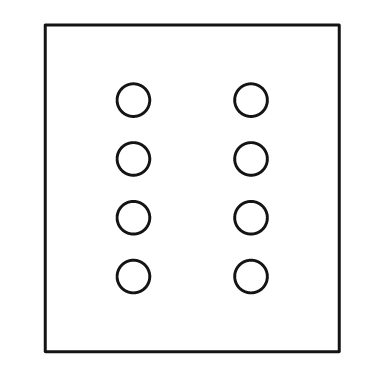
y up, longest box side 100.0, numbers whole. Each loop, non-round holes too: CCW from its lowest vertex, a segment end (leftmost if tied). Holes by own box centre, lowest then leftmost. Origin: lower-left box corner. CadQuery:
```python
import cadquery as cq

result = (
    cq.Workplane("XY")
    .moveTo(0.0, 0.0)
    .lineTo(90.0, 0.0)
    .lineTo(90.0, 100.0)
    .lineTo(0.0, 100.0)
    .close()
    .moveTo(27.0, 23.0)
    .circle(5.0)
    .moveTo(63.0, 23.0)
    .circle(5.0)
    .moveTo(27.0, 41.0)
    .circle(5.0)
    .moveTo(63.0, 41.0)
    .circle(5.0)
    .moveTo(27.0, 59.0)
    .circle(5.0)
    .moveTo(63.0, 59.0)
    .circle(5.0)
    .moveTo(27.0, 77.0)
    .circle(5.0)
    .moveTo(63.0, 77.0)
    .circle(5.0)
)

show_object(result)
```